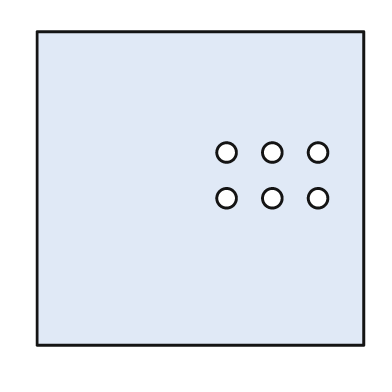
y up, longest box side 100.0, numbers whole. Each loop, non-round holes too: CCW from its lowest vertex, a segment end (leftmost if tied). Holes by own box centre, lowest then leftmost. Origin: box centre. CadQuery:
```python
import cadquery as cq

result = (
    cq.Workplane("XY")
    .moveTo(-50.0, -48.0)
    .lineTo(50.0, -48.0)
    .lineTo(50.0, 48.0)
    .lineTo(-50.0, 48.0)
    .close()
    .moveTo(8.0, -3.0)
    .circle(3.0)
    .moveTo(22.0, -3.0)
    .circle(3.0)
    .moveTo(36.0, -3.0)
    .circle(3.0)
    .moveTo(8.0, 11.0)
    .circle(3.0)
    .moveTo(22.0, 11.0)
    .circle(3.0)
    .moveTo(36.0, 11.0)
    .circle(3.0)
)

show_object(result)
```